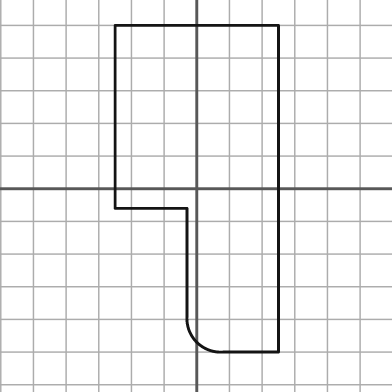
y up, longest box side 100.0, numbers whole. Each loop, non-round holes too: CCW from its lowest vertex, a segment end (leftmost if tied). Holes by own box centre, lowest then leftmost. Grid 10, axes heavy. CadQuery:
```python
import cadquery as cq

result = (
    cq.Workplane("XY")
    .moveTo(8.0, -50.0)
    .lineTo(25.0, -50.0)
    .lineTo(25.0, 50.0)
    .lineTo(-25.0, 50.0)
    .lineTo(-25.0, -6.0)
    .lineTo(-3.0, -6.0)
    .lineTo(-3.0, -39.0)
    .threePointArc((0.0, -47.0), (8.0, -50.0))
    .close()
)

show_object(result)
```